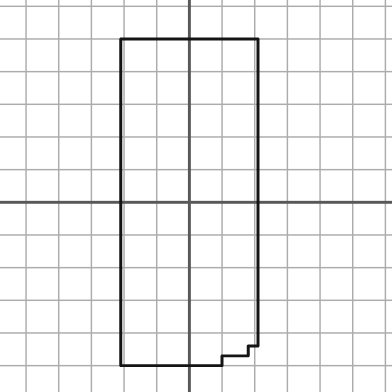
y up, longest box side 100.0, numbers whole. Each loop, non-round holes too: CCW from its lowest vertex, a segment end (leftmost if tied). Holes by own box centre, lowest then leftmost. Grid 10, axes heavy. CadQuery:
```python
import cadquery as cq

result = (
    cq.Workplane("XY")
    .moveTo(-21.0, -50.0)
    .lineTo(10.0, -50.0)
    .lineTo(10.0, -47.0)
    .lineTo(18.0, -47.0)
    .lineTo(18.0, -44.0)
    .lineTo(21.0, -44.0)
    .lineTo(21.0, 50.0)
    .lineTo(-21.0, 50.0)
    .close()
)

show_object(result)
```